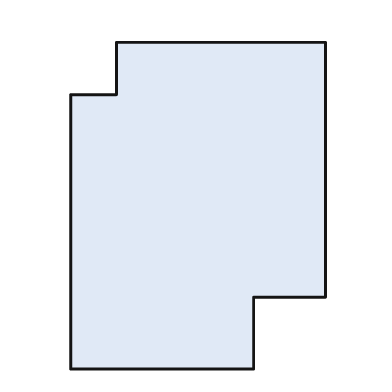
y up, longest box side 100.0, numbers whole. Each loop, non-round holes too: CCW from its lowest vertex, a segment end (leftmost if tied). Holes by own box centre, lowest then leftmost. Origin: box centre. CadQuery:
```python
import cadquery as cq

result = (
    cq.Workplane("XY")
    .moveTo(-39.0, -50.0)
    .lineTo(17.0, -50.0)
    .lineTo(17.0, -28.0)
    .lineTo(39.0, -28.0)
    .lineTo(39.0, 50.0)
    .lineTo(-25.0, 50.0)
    .lineTo(-25.0, 34.0)
    .lineTo(-39.0, 34.0)
    .close()
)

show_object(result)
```